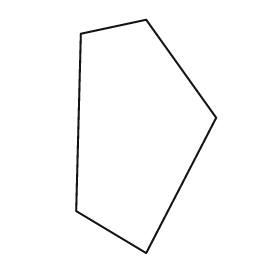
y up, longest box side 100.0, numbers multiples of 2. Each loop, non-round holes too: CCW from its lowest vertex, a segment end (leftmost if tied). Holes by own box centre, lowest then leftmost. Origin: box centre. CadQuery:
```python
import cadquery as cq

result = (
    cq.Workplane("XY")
    .moveTo(0.0, -50.0)
    .lineTo(30.0, 8.0)
    .lineTo(0.0, 50.0)
    .lineTo(-28.0, 44.0)
    .lineTo(-30.0, -32.0)
    .close()
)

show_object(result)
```